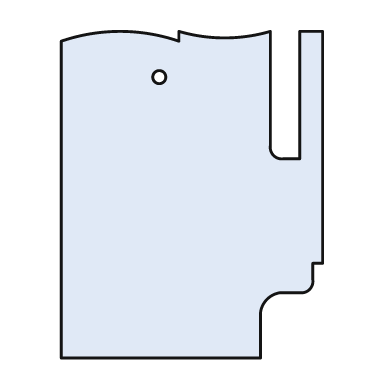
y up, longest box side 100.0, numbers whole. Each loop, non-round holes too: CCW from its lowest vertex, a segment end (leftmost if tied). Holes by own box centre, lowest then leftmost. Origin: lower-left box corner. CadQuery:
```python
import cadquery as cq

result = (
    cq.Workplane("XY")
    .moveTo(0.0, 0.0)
    .lineTo(61.0, 0.0)
    .lineTo(61.0, 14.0)
    .threePointArc((63.0, 18.0), (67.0, 20.0))
    .lineTo(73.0, 20.0)
    .threePointArc((76.0, 21.0), (77.0, 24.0))
    .lineTo(77.0, 29.0)
    .lineTo(80.0, 29.0)
    .lineTo(80.0, 100.0)
    .lineTo(73.0, 100.0)
    .lineTo(73.0, 61.0)
    .lineTo(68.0, 61.0)
    .threePointArc((65.0, 62.0), (64.0, 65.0))
    .lineTo(64.0, 100.0)
    .threePointArc((50.0, 98.0), (36.0, 100.0))
    .lineTo(36.0, 97.0)
    .threePointArc((18.0, 100.0), (0.0, 97.0))
    .close()
    .moveTo(30.0, 86.0)
    .circle(2.0)
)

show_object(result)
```